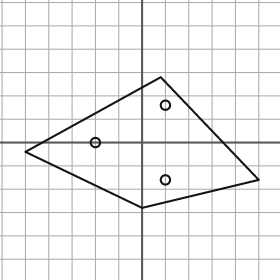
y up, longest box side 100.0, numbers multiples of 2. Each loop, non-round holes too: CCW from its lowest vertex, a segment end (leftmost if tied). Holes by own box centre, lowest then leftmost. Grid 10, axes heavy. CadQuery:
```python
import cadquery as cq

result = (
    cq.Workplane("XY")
    .moveTo(0.0, -28.0)
    .lineTo(50.0, -16.0)
    .lineTo(8.0, 28.0)
    .lineTo(-50.0, -4.0)
    .close()
    .moveTo(10.0, -16.0)
    .circle(2.0)
    .moveTo(-20.0, 0.0)
    .circle(2.0)
    .moveTo(10.0, 16.0)
    .circle(2.0)
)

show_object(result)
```